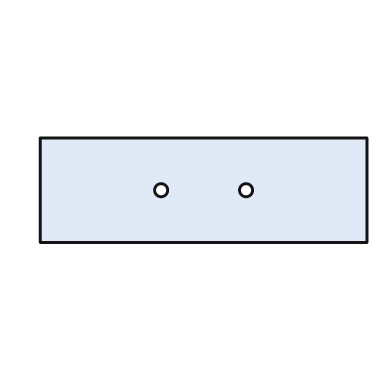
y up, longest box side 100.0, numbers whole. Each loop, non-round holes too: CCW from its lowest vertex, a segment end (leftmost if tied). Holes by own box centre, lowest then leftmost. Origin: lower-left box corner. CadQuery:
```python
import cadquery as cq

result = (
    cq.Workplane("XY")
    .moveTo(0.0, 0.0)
    .lineTo(100.0, 0.0)
    .lineTo(100.0, 32.0)
    .lineTo(0.0, 32.0)
    .close()
    .moveTo(37.0, 16.0)
    .circle(2.0)
    .moveTo(63.0, 16.0)
    .circle(2.0)
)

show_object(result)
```